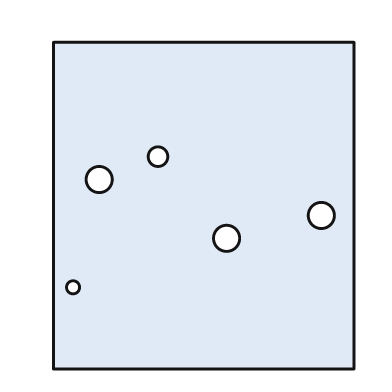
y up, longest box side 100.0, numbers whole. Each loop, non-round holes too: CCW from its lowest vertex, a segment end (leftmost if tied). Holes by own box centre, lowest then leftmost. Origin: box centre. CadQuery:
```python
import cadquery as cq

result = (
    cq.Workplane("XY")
    .moveTo(-46.0, -50.0)
    .lineTo(46.0, -50.0)
    .lineTo(46.0, 50.0)
    .lineTo(-46.0, 50.0)
    .close()
    .moveTo(-40.0, -25.0)
    .circle(2.0)
    .moveTo(7.0, -10.0)
    .circle(4.0)
    .moveTo(36.0, -3.0)
    .circle(4.0)
    .moveTo(-32.0, 8.0)
    .circle(4.0)
    .moveTo(-14.0, 15.0)
    .circle(3.0)
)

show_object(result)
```